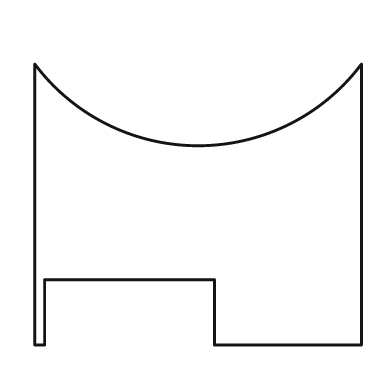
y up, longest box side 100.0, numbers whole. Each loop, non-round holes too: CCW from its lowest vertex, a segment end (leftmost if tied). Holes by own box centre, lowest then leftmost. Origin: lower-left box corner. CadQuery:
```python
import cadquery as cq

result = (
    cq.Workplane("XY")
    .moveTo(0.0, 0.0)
    .lineTo(3.0, 0.0)
    .lineTo(3.0, 20.0)
    .lineTo(55.0, 20.0)
    .lineTo(55.0, 0.0)
    .lineTo(100.0, 0.0)
    .lineTo(100.0, 86.0)
    .threePointArc((50.0, 61.0), (0.0, 86.0))
    .close()
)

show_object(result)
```